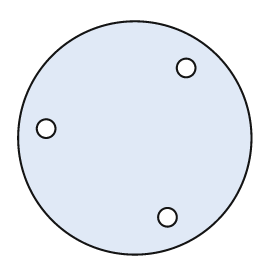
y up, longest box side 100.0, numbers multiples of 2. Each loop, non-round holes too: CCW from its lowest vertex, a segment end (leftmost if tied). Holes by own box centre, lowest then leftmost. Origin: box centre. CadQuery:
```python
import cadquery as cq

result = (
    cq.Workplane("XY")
    .moveTo(0.0, 0.0)
    .circle(50.0)
    .moveTo(14.0, -34.0)
    .circle(4.0)
    .moveTo(-38.0, 4.0)
    .circle(4.0)
    .moveTo(22.0, 30.0)
    .circle(4.0)
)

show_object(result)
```